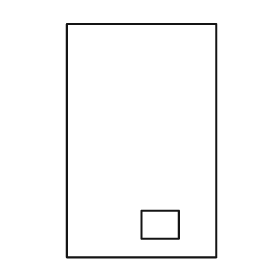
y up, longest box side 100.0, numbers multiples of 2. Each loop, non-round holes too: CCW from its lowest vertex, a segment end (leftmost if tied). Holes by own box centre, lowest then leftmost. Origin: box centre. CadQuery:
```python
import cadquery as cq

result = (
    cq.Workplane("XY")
    .moveTo(-32.0, -50.0)
    .lineTo(32.0, -50.0)
    .lineTo(32.0, 50.0)
    .lineTo(-32.0, 50.0)
    .close()
    .moveTo(0.0, -42.0)
    .lineTo(16.0, -42.0)
    .lineTo(16.0, -30.0)
    .lineTo(0.0, -30.0)
    .close()
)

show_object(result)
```